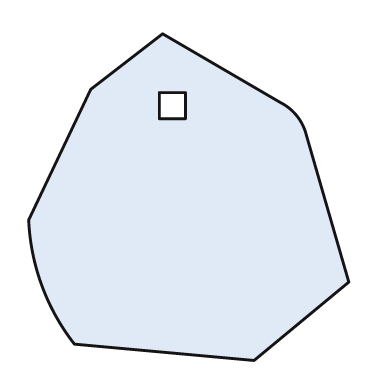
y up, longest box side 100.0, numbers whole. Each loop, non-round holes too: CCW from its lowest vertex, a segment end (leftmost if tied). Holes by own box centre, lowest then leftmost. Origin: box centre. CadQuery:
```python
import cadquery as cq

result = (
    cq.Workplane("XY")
    .moveTo(20.0, -50.0)
    .lineTo(49.0, -26.0)
    .lineTo(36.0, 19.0)
    .threePointArc((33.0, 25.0), (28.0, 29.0))
    .lineTo(-8.0, 50.0)
    .lineTo(-30.0, 33.0)
    .lineTo(-49.0, -7.0)
    .threePointArc((-45.0, -27.0), (-35.0, -45.0))
    .close()
    .moveTo(-9.0, 24.0)
    .lineTo(-1.0, 24.0)
    .lineTo(-1.0, 32.0)
    .lineTo(-9.0, 32.0)
    .close()
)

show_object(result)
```